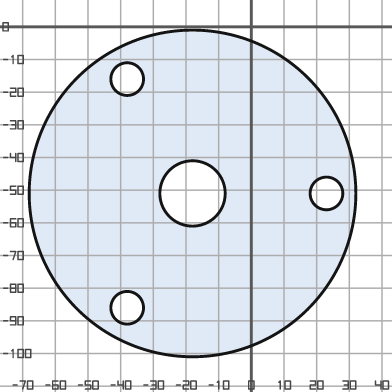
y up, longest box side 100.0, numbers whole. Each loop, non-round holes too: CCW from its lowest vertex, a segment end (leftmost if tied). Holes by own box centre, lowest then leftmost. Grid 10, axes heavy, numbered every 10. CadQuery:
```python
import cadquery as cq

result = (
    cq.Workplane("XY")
    .moveTo(-18.0, -51.0)
    .circle(50.0)
    .moveTo(-38.0, -86.0)
    .circle(5.0)
    .moveTo(-18.0, -51.0)
    .circle(10.0)
    .moveTo(23.0, -51.0)
    .circle(5.0)
    .moveTo(-38.0, -16.0)
    .circle(5.0)
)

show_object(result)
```